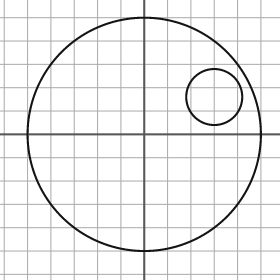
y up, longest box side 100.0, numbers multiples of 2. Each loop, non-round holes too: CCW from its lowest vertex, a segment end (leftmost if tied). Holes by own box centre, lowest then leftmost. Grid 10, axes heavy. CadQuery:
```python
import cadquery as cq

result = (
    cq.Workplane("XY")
    .moveTo(0.0, 0.0)
    .circle(50.0)
    .moveTo(30.0, 16.0)
    .circle(12.0)
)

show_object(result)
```